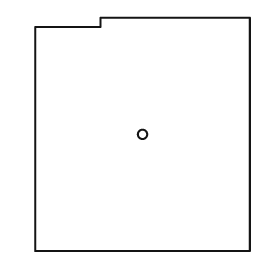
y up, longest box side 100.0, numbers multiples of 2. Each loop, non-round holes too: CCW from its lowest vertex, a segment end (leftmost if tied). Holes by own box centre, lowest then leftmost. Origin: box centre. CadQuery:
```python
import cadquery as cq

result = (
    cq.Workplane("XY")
    .moveTo(-46.0, -50.0)
    .lineTo(46.0, -50.0)
    .lineTo(46.0, 50.0)
    .lineTo(-18.0, 50.0)
    .lineTo(-18.0, 46.0)
    .lineTo(-46.0, 46.0)
    .close()
    .moveTo(0.0, 0.0)
    .circle(2.0)
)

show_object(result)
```